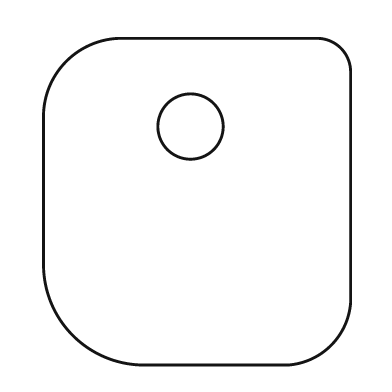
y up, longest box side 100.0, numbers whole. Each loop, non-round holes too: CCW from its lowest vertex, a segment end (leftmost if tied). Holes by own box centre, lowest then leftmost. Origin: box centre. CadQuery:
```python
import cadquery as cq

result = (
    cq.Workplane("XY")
    .moveTo(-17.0, -50.0)
    .lineTo(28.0, -50.0)
    .threePointArc((41.0, -44.0), (47.0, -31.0))
    .lineTo(47.0, 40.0)
    .threePointArc((44.0, 47.0), (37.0, 50.0))
    .lineTo(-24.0, 50.0)
    .threePointArc((-40.0, 43.0), (-47.0, 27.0))
    .lineTo(-47.0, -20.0)
    .threePointArc((-38.0, -41.0), (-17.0, -50.0))
    .close()
    .moveTo(-2.0, 23.0)
    .circle(10.0)
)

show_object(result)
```